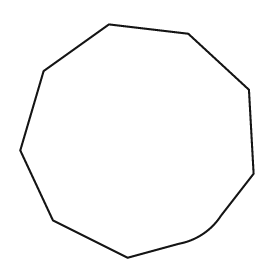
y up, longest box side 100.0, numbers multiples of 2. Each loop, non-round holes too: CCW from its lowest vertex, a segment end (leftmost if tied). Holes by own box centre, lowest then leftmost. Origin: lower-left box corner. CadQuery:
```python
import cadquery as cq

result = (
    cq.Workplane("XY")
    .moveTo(46.0, 0.0)
    .lineTo(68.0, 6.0)
    .threePointArc((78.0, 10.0), (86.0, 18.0))
    .lineTo(100.0, 36.0)
    .lineTo(98.0, 72.0)
    .lineTo(72.0, 96.0)
    .lineTo(38.0, 100.0)
    .lineTo(10.0, 80.0)
    .lineTo(0.0, 46.0)
    .lineTo(14.0, 16.0)
    .close()
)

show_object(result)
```